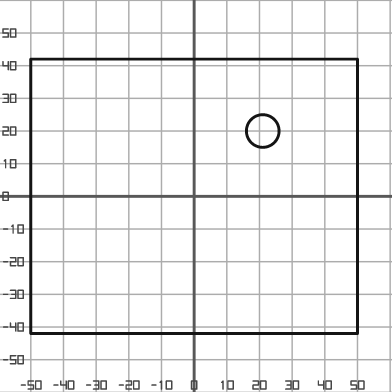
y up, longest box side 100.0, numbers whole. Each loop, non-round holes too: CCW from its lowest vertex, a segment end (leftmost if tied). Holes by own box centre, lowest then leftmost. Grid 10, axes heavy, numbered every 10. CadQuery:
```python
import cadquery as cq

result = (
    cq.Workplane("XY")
    .moveTo(-50.0, -42.0)
    .lineTo(50.0, -42.0)
    .lineTo(50.0, 42.0)
    .lineTo(-50.0, 42.0)
    .close()
    .moveTo(21.0, 20.0)
    .circle(5.0)
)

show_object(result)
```